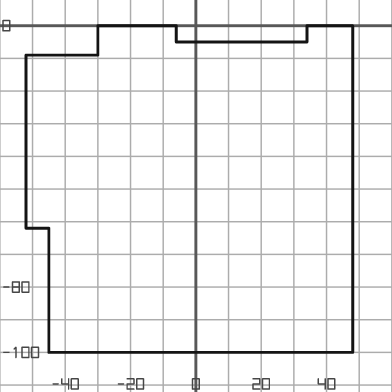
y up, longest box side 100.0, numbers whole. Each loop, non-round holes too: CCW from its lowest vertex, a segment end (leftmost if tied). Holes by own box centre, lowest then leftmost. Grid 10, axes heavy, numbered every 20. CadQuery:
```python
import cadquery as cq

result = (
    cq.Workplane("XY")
    .moveTo(-45.0, -100.0)
    .lineTo(48.0, -100.0)
    .lineTo(48.0, 0.0)
    .lineTo(34.0, 0.0)
    .lineTo(34.0, -5.0)
    .lineTo(-6.0, -5.0)
    .lineTo(-6.0, 0.0)
    .lineTo(-30.0, 0.0)
    .lineTo(-30.0, -9.0)
    .lineTo(-52.0, -9.0)
    .lineTo(-52.0, -62.0)
    .lineTo(-45.0, -62.0)
    .close()
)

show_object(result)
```